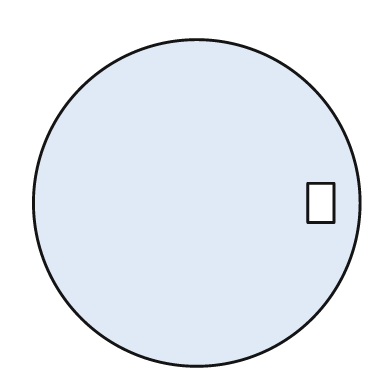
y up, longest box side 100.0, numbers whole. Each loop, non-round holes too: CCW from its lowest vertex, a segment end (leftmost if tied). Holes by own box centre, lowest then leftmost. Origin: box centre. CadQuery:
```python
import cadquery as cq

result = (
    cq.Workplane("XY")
    .moveTo(0.0, 0.0)
    .circle(50.0)
    .moveTo(34.0, -6.0)
    .lineTo(42.0, -6.0)
    .lineTo(42.0, 6.0)
    .lineTo(34.0, 6.0)
    .close()
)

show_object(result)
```